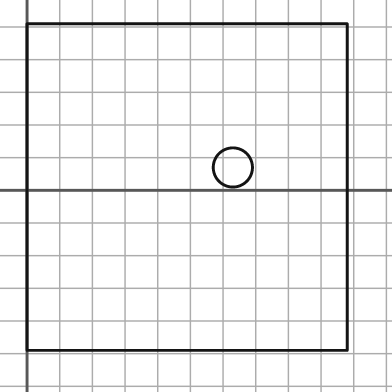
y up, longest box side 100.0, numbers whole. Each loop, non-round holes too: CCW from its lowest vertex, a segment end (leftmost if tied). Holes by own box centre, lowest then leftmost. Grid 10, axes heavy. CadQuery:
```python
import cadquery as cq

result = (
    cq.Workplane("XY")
    .moveTo(0.0, -49.0)
    .lineTo(98.0, -49.0)
    .lineTo(98.0, 51.0)
    .lineTo(0.0, 51.0)
    .close()
    .moveTo(63.0, 7.0)
    .circle(6.0)
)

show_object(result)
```